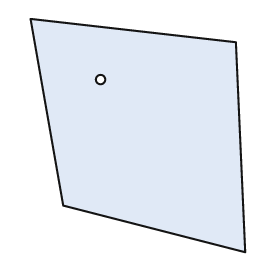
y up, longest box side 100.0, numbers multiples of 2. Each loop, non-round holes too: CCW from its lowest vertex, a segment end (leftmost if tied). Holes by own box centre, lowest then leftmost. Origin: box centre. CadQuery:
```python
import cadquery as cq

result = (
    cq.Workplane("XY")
    .moveTo(46.0, -50.0)
    .lineTo(42.0, 40.0)
    .lineTo(-46.0, 50.0)
    .lineTo(-32.0, -30.0)
    .close()
    .moveTo(-16.0, 24.0)
    .circle(2.0)
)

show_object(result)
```